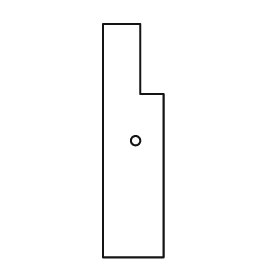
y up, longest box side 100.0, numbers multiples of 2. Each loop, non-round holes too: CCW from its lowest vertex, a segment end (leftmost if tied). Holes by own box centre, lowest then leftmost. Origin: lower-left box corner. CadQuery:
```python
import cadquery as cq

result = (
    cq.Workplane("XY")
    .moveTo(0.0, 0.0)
    .lineTo(26.0, 0.0)
    .lineTo(26.0, 70.0)
    .lineTo(16.0, 70.0)
    .lineTo(16.0, 100.0)
    .lineTo(0.0, 100.0)
    .close()
    .moveTo(14.0, 50.0)
    .circle(2.0)
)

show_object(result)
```